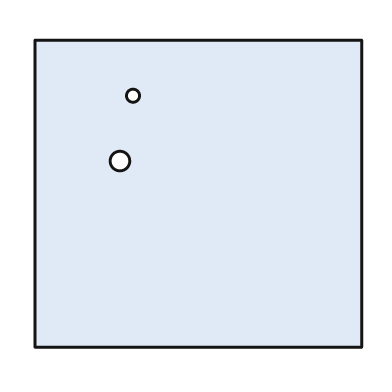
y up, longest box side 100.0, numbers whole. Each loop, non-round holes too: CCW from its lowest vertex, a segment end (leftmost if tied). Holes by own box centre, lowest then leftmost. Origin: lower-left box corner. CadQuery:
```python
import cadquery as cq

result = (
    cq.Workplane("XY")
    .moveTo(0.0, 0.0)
    .lineTo(100.0, 0.0)
    .lineTo(100.0, 94.0)
    .lineTo(0.0, 94.0)
    .close()
    .moveTo(26.0, 57.0)
    .circle(3.0)
    .moveTo(30.0, 77.0)
    .circle(2.0)
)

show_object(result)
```